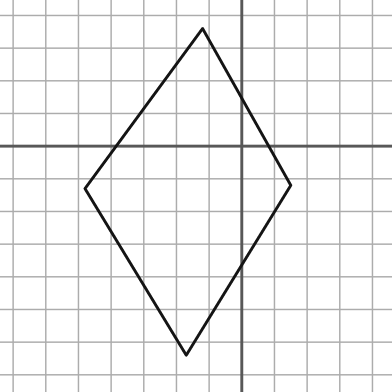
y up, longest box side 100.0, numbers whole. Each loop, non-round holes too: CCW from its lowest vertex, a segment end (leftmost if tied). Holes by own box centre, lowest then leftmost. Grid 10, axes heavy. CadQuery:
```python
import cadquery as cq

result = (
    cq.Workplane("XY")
    .moveTo(-17.0, -64.0)
    .lineTo(15.0, -12.0)
    .lineTo(-12.0, 36.0)
    .lineTo(-48.0, -13.0)
    .close()
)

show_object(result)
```